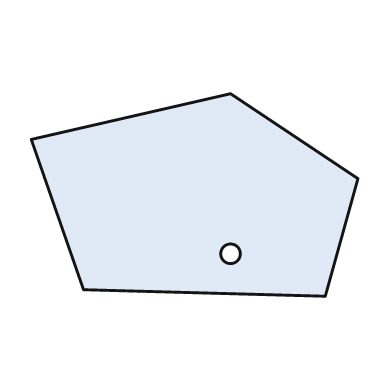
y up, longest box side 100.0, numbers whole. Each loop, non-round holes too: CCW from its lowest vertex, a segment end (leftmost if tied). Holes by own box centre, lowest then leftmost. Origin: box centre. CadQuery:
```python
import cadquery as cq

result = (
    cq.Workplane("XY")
    .moveTo(40.0, -31.0)
    .lineTo(50.0, 5.0)
    .lineTo(11.0, 31.0)
    .lineTo(-50.0, 17.0)
    .lineTo(-34.0, -29.0)
    .close()
    .moveTo(11.0, -18.0)
    .circle(3.0)
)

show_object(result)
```